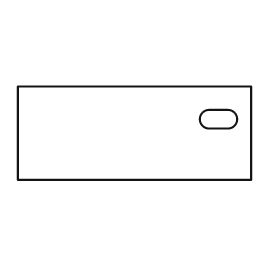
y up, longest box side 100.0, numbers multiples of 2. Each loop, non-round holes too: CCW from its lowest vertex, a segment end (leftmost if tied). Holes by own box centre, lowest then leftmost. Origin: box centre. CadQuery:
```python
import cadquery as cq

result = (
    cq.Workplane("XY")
    .moveTo(-50.0, -20.0)
    .lineTo(50.0, -20.0)
    .lineTo(50.0, 20.0)
    .lineTo(-50.0, 20.0)
    .close()
    .moveTo(32.0, 2.0)
    .lineTo(40.0, 2.0)
    .threePointArc((44.0, 6.0), (40.0, 10.0))
    .lineTo(32.0, 10.0)
    .threePointArc((28.0, 6.0), (32.0, 2.0))
    .close()
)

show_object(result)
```